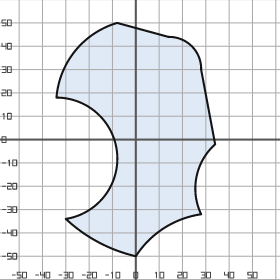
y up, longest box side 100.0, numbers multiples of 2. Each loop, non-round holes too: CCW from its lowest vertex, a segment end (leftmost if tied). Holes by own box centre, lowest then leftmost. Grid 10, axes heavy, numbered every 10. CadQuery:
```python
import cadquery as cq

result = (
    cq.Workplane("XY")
    .moveTo(0.0, -50.0)
    .threePointArc((12.0, -38.0), (28.0, -32.0))
    .threePointArc((26.0, -16.0), (34.0, -2.0))
    .lineTo(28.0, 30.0)
    .threePointArc((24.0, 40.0), (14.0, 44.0))
    .lineTo(-8.0, 50.0)
    .threePointArc((-26.0, 38.0), (-34.0, 18.0))
    .threePointArc((-8.0, -6.0), (-30.0, -34.0))
    .threePointArc((-16.0, -44.0), (0.0, -50.0))
    .close()
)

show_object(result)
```